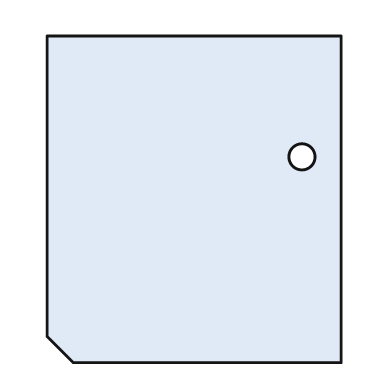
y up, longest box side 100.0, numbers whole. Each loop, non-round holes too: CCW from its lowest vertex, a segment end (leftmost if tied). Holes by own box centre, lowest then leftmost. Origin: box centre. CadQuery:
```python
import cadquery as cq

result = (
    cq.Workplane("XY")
    .moveTo(-37.0, -50.0)
    .lineTo(45.0, -50.0)
    .lineTo(45.0, 50.0)
    .lineTo(-45.0, 50.0)
    .lineTo(-45.0, -42.0)
    .close()
    .moveTo(33.0, 13.0)
    .circle(4.0)
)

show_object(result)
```